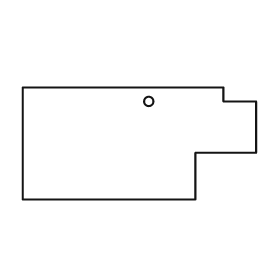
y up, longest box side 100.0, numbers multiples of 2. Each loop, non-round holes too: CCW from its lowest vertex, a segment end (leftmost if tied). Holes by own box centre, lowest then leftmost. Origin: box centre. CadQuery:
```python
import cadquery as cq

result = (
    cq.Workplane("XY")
    .moveTo(-50.0, -24.0)
    .lineTo(24.0, -24.0)
    .lineTo(24.0, -4.0)
    .lineTo(50.0, -4.0)
    .lineTo(50.0, 18.0)
    .lineTo(36.0, 18.0)
    .lineTo(36.0, 24.0)
    .lineTo(-50.0, 24.0)
    .close()
    .moveTo(4.0, 18.0)
    .circle(2.0)
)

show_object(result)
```